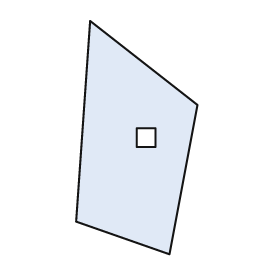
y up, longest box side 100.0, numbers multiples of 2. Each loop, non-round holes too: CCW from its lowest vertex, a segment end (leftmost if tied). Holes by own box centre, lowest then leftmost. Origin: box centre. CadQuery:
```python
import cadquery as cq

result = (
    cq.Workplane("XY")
    .moveTo(14.0, -50.0)
    .lineTo(26.0, 14.0)
    .lineTo(-20.0, 50.0)
    .lineTo(-26.0, -36.0)
    .close()
    .moveTo(0.0, -4.0)
    .lineTo(8.0, -4.0)
    .lineTo(8.0, 4.0)
    .lineTo(0.0, 4.0)
    .close()
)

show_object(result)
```